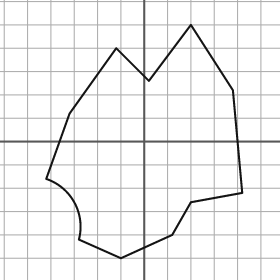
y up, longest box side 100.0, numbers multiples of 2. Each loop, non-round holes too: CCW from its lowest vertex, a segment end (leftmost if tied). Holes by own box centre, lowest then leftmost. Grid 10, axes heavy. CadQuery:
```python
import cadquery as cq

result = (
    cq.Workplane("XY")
    .moveTo(-10.0, -50.0)
    .lineTo(12.0, -40.0)
    .lineTo(20.0, -26.0)
    .lineTo(42.0, -22.0)
    .lineTo(38.0, 22.0)
    .lineTo(20.0, 50.0)
    .lineTo(2.0, 26.0)
    .lineTo(-12.0, 40.0)
    .lineTo(-32.0, 12.0)
    .lineTo(-42.0, -16.0)
    .threePointArc((-30.0, -26.0), (-28.0, -42.0))
    .close()
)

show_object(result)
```